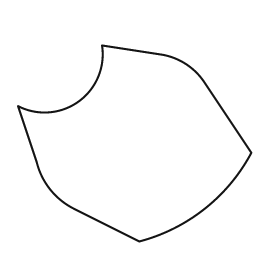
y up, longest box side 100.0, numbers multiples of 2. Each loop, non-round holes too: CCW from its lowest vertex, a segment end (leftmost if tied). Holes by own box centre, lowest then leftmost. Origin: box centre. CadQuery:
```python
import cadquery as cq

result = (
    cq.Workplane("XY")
    .moveTo(2.0, -42.0)
    .threePointArc((30.0, -28.0), (50.0, -4.0))
    .lineTo(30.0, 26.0)
    .threePointArc((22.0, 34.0), (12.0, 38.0))
    .lineTo(-14.0, 42.0)
    .threePointArc((-24.0, 18.0), (-50.0, 16.0))
    .lineTo(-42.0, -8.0)
    .threePointArc((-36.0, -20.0), (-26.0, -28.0))
    .close()
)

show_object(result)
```